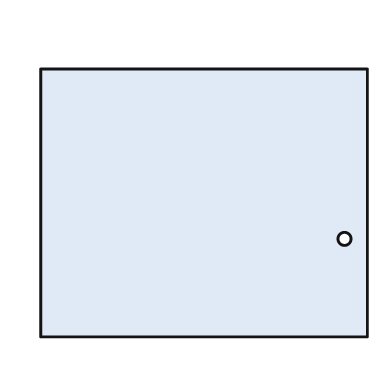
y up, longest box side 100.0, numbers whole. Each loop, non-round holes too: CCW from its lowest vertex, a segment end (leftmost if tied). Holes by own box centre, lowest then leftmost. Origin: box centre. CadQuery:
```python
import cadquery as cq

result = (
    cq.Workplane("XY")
    .moveTo(-50.0, -41.0)
    .lineTo(50.0, -41.0)
    .lineTo(50.0, 41.0)
    .lineTo(-50.0, 41.0)
    .close()
    .moveTo(43.0, -11.0)
    .circle(2.0)
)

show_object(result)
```